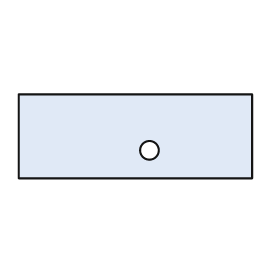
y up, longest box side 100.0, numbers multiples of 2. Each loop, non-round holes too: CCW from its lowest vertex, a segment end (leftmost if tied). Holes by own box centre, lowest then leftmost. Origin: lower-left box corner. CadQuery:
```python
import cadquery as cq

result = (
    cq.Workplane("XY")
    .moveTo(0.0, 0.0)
    .lineTo(100.0, 0.0)
    .lineTo(100.0, 36.0)
    .lineTo(0.0, 36.0)
    .close()
    .moveTo(56.0, 12.0)
    .circle(4.0)
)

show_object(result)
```